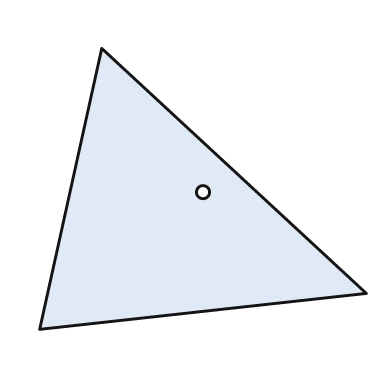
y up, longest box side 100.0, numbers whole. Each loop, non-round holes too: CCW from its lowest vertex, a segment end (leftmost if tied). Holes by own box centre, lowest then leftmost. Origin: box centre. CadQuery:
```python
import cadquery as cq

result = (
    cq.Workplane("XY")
    .moveTo(-50.0, -43.0)
    .lineTo(50.0, -32.0)
    .lineTo(-31.0, 43.0)
    .close()
    .moveTo(0.0, -1.0)
    .circle(2.0)
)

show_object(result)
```